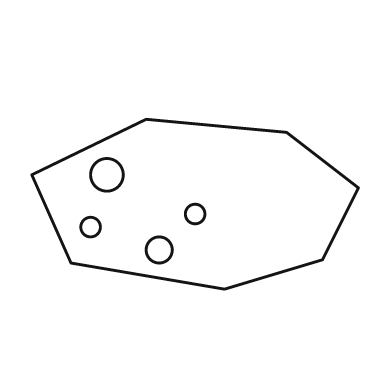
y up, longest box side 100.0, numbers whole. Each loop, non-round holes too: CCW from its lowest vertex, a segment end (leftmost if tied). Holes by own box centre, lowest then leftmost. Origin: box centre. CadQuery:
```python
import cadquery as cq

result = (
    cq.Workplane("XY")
    .moveTo(9.0, -26.0)
    .lineTo(39.0, -17.0)
    .lineTo(50.0, 5.0)
    .lineTo(28.0, 22.0)
    .lineTo(-15.0, 26.0)
    .lineTo(-50.0, 9.0)
    .lineTo(-38.0, -18.0)
    .close()
    .moveTo(-11.0, -14.0)
    .circle(4.0)
    .moveTo(-32.0, -7.0)
    .circle(3.0)
    .moveTo(0.0, -3.0)
    .circle(3.0)
    .moveTo(-27.0, 9.0)
    .circle(5.0)
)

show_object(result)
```